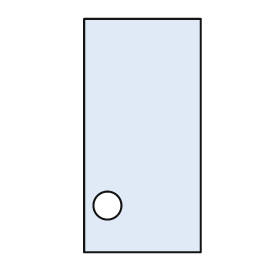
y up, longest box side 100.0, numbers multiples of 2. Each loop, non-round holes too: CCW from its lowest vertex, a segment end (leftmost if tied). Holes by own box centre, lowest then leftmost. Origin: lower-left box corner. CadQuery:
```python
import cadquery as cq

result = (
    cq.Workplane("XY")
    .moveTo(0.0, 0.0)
    .lineTo(50.0, 0.0)
    .lineTo(50.0, 100.0)
    .lineTo(0.0, 100.0)
    .close()
    .moveTo(10.0, 20.0)
    .circle(6.0)
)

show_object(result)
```